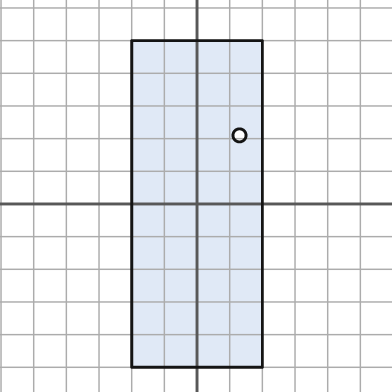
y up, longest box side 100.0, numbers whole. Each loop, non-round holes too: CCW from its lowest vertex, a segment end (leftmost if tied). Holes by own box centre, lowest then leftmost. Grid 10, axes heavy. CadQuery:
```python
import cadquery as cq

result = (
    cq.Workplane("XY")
    .moveTo(-20.0, -50.0)
    .lineTo(20.0, -50.0)
    .lineTo(20.0, 50.0)
    .lineTo(-20.0, 50.0)
    .close()
    .moveTo(13.0, 21.0)
    .circle(2.0)
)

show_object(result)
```